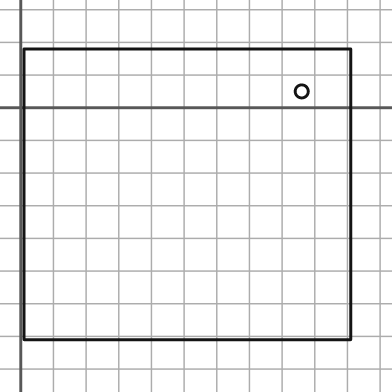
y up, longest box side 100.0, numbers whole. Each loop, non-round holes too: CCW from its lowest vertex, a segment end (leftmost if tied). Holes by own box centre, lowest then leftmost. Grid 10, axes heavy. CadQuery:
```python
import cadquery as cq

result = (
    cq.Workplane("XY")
    .moveTo(1.0, -71.0)
    .lineTo(101.0, -71.0)
    .lineTo(101.0, 18.0)
    .lineTo(1.0, 18.0)
    .close()
    .moveTo(86.0, 5.0)
    .circle(2.0)
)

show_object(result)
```